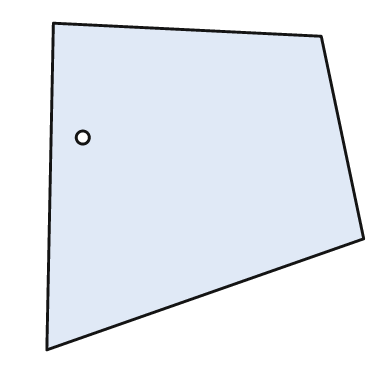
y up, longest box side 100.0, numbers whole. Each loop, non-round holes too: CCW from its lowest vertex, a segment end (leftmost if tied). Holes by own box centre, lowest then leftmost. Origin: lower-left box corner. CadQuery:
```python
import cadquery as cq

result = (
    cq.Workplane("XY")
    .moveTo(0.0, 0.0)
    .lineTo(97.0, 34.0)
    .lineTo(84.0, 96.0)
    .lineTo(2.0, 100.0)
    .close()
    .moveTo(11.0, 65.0)
    .circle(2.0)
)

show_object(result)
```